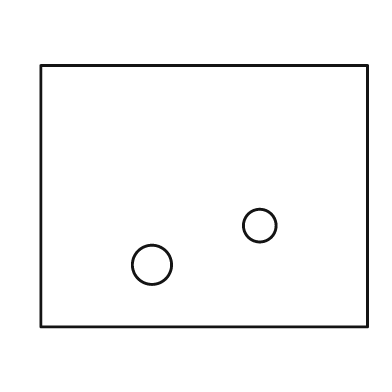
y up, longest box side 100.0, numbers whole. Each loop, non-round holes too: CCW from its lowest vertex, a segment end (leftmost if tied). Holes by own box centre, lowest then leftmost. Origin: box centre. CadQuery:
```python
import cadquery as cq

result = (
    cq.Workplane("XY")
    .moveTo(-50.0, -40.0)
    .lineTo(50.0, -40.0)
    .lineTo(50.0, 40.0)
    .lineTo(-50.0, 40.0)
    .close()
    .moveTo(-16.0, -21.0)
    .circle(6.0)
    .moveTo(17.0, -9.0)
    .circle(5.0)
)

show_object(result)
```